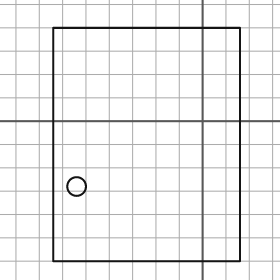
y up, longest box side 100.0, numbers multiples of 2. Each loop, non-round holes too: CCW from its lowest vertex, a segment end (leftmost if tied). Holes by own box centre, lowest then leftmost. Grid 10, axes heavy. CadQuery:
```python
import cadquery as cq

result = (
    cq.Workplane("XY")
    .moveTo(-64.0, -60.0)
    .lineTo(16.0, -60.0)
    .lineTo(16.0, 40.0)
    .lineTo(-64.0, 40.0)
    .close()
    .moveTo(-54.0, -28.0)
    .circle(4.0)
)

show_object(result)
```